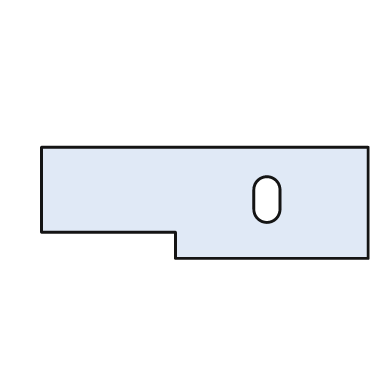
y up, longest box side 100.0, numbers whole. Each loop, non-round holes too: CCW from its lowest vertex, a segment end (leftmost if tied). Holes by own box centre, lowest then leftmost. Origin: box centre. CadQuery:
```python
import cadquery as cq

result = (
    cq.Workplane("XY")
    .moveTo(-9.0, -17.0)
    .lineTo(50.0, -17.0)
    .lineTo(50.0, 17.0)
    .lineTo(-50.0, 17.0)
    .lineTo(-50.0, -9.0)
    .lineTo(-9.0, -9.0)
    .close()
    .moveTo(15.0, -2.0)
    .threePointArc((19.0, -6.0), (23.0, -2.0))
    .lineTo(23.0, 4.0)
    .threePointArc((19.0, 8.0), (15.0, 4.0))
    .close()
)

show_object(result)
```